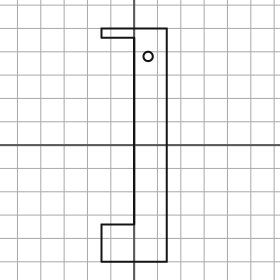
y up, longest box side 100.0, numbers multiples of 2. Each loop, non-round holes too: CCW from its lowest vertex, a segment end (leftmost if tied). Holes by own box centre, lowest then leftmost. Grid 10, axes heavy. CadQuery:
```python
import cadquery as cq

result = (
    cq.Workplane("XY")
    .moveTo(-14.0, -50.0)
    .lineTo(14.0, -50.0)
    .lineTo(14.0, 50.0)
    .lineTo(-14.0, 50.0)
    .lineTo(-14.0, 46.0)
    .lineTo(0.0, 46.0)
    .lineTo(0.0, -34.0)
    .lineTo(-14.0, -34.0)
    .close()
    .moveTo(6.0, 38.0)
    .circle(2.0)
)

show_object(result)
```